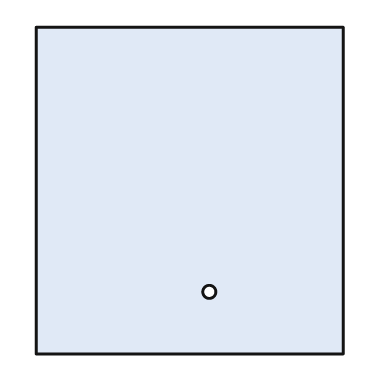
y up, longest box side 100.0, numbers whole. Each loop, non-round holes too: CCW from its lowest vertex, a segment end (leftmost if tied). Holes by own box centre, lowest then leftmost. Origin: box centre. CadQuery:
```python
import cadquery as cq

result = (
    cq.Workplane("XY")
    .moveTo(-47.0, -50.0)
    .lineTo(47.0, -50.0)
    .lineTo(47.0, 50.0)
    .lineTo(-47.0, 50.0)
    .close()
    .moveTo(6.0, -31.0)
    .circle(2.0)
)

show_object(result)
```